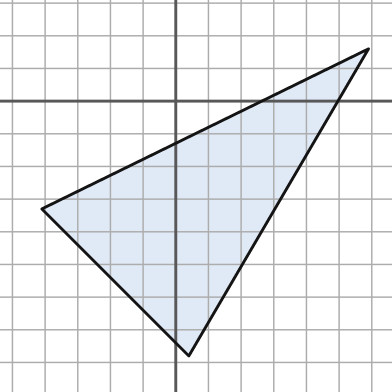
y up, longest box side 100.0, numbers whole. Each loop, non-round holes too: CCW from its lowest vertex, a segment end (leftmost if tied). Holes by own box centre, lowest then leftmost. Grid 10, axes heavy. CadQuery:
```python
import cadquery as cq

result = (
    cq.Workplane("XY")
    .moveTo(4.0, -78.0)
    .lineTo(59.0, 16.0)
    .lineTo(-41.0, -33.0)
    .close()
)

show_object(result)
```